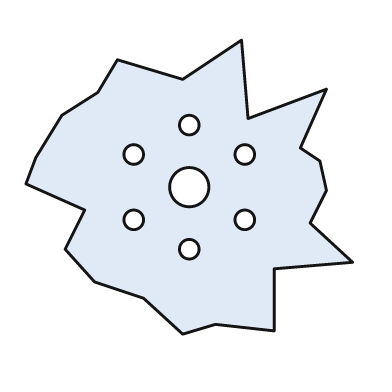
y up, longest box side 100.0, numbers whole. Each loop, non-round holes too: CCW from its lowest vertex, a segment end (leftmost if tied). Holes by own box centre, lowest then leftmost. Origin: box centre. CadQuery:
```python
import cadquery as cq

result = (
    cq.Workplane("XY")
    .moveTo(-2.0, -45.0)
    .lineTo(8.0, -42.0)
    .lineTo(26.0, -44.0)
    .lineTo(26.0, -25.0)
    .lineTo(50.0, -23.0)
    .lineTo(37.0, -11.0)
    .lineTo(42.0, -1.0)
    .lineTo(40.0, 8.0)
    .lineTo(34.0, 12.0)
    .lineTo(42.0, 30.0)
    .lineTo(18.0, 21.0)
    .lineTo(16.0, 45.0)
    .lineTo(-2.0, 33.0)
    .lineTo(-22.0, 39.0)
    .lineTo(-28.0, 29.0)
    .lineTo(-39.0, 22.0)
    .lineTo(-47.0, 9.0)
    .lineTo(-50.0, 1.0)
    .lineTo(-32.0, -7.0)
    .lineTo(-38.0, -19.0)
    .lineTo(-29.0, -29.0)
    .lineTo(-14.0, -34.0)
    .close()
    .moveTo(0.0, -19.0)
    .circle(3.0)
    .moveTo(-17.0, -10.0)
    .circle(3.0)
    .moveTo(17.0, -10.0)
    .circle(3.0)
    .moveTo(0.0, 0.0)
    .circle(6.0)
    .moveTo(-17.0, 10.0)
    .circle(3.0)
    .moveTo(17.0, 10.0)
    .circle(3.0)
    .moveTo(0.0, 19.0)
    .circle(3.0)
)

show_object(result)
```